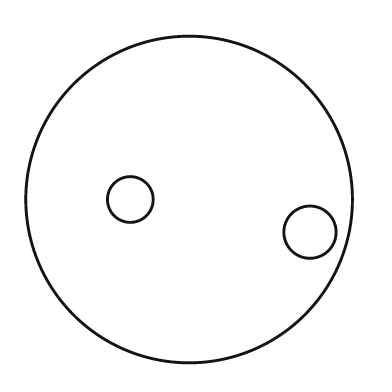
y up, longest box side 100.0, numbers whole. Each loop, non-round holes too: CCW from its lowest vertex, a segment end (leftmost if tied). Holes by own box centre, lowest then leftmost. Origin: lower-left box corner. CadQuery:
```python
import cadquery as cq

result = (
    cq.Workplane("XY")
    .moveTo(50.0, 50.0)
    .circle(50.0)
    .moveTo(87.0, 40.0)
    .circle(8.0)
    .moveTo(32.0, 50.0)
    .circle(7.0)
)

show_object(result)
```